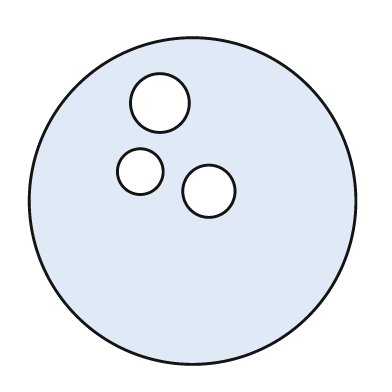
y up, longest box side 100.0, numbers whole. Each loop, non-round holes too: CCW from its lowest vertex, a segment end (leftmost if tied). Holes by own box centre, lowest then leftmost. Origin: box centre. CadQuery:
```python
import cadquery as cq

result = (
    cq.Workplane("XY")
    .moveTo(0.0, 0.0)
    .circle(50.0)
    .moveTo(5.0, 3.0)
    .circle(8.0)
    .moveTo(-16.0, 9.0)
    .circle(7.0)
    .moveTo(-10.0, 30.0)
    .circle(9.0)
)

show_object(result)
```